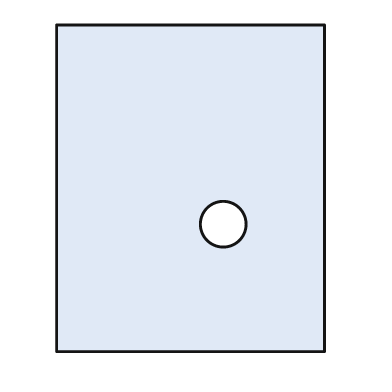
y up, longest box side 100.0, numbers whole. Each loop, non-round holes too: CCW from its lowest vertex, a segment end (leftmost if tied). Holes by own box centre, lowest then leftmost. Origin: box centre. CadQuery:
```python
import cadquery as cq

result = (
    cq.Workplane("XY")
    .moveTo(-41.0, -50.0)
    .lineTo(41.0, -50.0)
    .lineTo(41.0, 50.0)
    .lineTo(-41.0, 50.0)
    .close()
    .moveTo(10.0, -11.0)
    .circle(7.0)
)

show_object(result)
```